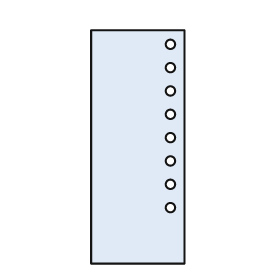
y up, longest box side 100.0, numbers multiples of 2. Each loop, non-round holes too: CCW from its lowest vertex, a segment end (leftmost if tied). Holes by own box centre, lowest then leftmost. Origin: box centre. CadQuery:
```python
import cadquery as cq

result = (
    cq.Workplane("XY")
    .moveTo(-20.0, -50.0)
    .lineTo(20.0, -50.0)
    .lineTo(20.0, 50.0)
    .lineTo(-20.0, 50.0)
    .close()
    .moveTo(14.0, -26.0)
    .circle(2.0)
    .moveTo(14.0, -16.0)
    .circle(2.0)
    .moveTo(14.0, -6.0)
    .circle(2.0)
    .moveTo(14.0, 4.0)
    .circle(2.0)
    .moveTo(14.0, 14.0)
    .circle(2.0)
    .moveTo(14.0, 24.0)
    .circle(2.0)
    .moveTo(14.0, 34.0)
    .circle(2.0)
    .moveTo(14.0, 44.0)
    .circle(2.0)
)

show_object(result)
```